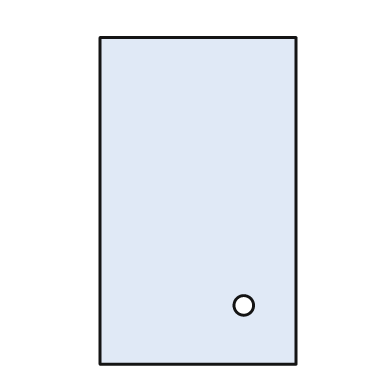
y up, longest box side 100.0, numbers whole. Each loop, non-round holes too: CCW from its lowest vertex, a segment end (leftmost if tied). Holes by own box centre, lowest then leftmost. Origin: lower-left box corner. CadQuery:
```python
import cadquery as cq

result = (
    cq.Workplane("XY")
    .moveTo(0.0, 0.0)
    .lineTo(60.0, 0.0)
    .lineTo(60.0, 100.0)
    .lineTo(0.0, 100.0)
    .close()
    .moveTo(44.0, 18.0)
    .circle(3.0)
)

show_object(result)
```